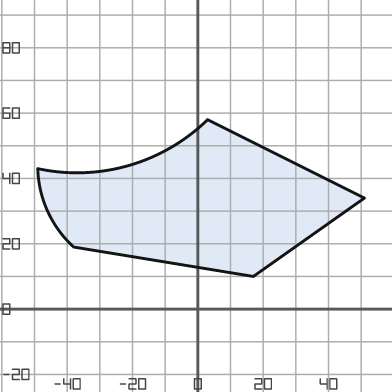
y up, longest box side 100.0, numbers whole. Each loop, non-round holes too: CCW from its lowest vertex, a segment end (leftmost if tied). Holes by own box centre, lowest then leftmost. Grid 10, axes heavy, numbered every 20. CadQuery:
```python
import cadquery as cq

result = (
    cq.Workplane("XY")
    .moveTo(17.0, 10.0)
    .lineTo(51.0, 34.0)
    .lineTo(3.0, 58.0)
    .threePointArc((-21.0, 44.0), (-49.0, 43.0))
    .threePointArc((-46.0, 30.0), (-38.0, 19.0))
    .close()
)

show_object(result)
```